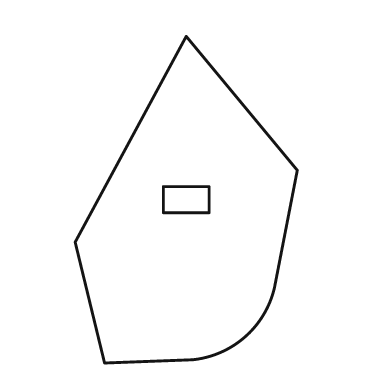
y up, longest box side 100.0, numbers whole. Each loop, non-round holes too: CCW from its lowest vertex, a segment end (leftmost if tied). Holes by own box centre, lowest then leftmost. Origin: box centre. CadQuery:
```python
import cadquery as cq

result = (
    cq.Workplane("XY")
    .moveTo(-25.0, -50.0)
    .lineTo(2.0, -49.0)
    .threePointArc((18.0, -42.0), (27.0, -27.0))
    .lineTo(34.0, 9.0)
    .lineTo(0.0, 50.0)
    .lineTo(-34.0, -13.0)
    .close()
    .moveTo(-7.0, -4.0)
    .lineTo(7.0, -4.0)
    .lineTo(7.0, 4.0)
    .lineTo(-7.0, 4.0)
    .close()
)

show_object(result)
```